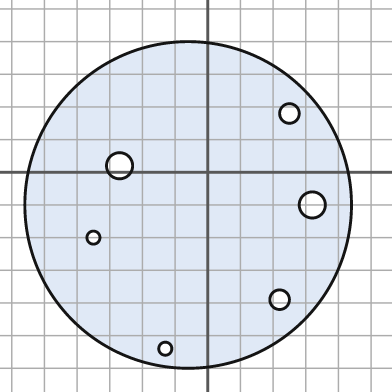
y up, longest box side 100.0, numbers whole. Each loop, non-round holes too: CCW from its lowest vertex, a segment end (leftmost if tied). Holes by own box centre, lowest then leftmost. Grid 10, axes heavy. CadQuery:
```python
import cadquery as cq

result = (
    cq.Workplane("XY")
    .moveTo(-6.0, -10.0)
    .circle(50.0)
    .moveTo(-13.0, -54.0)
    .circle(2.0)
    .moveTo(22.0, -39.0)
    .circle(3.0)
    .moveTo(-35.0, -20.0)
    .circle(2.0)
    .moveTo(32.0, -10.0)
    .circle(4.0)
    .moveTo(-27.0, 2.0)
    .circle(4.0)
    .moveTo(25.0, 18.0)
    .circle(3.0)
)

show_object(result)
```